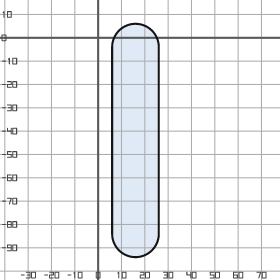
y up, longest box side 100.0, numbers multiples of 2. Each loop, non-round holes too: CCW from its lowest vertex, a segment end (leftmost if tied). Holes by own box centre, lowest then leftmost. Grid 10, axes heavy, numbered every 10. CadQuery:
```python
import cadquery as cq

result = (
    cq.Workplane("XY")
    .moveTo(6.0, -84.0)
    .threePointArc((16.0, -94.0), (26.0, -84.0))
    .lineTo(26.0, -4.0)
    .threePointArc((16.0, 6.0), (6.0, -4.0))
    .close()
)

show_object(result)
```